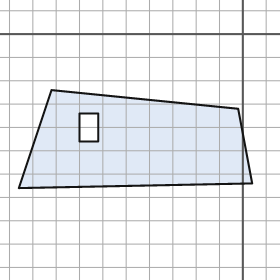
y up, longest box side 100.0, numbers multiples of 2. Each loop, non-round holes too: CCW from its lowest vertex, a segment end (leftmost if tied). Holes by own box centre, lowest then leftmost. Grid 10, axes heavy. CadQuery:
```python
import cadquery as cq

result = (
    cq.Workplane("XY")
    .moveTo(-96.0, -66.0)
    .lineTo(4.0, -64.0)
    .lineTo(-2.0, -32.0)
    .lineTo(-82.0, -24.0)
    .close()
    .moveTo(-70.0, -46.0)
    .lineTo(-62.0, -46.0)
    .lineTo(-62.0, -34.0)
    .lineTo(-70.0, -34.0)
    .close()
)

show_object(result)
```